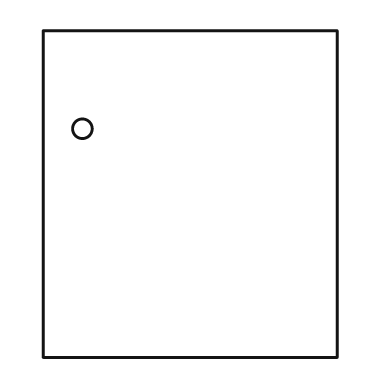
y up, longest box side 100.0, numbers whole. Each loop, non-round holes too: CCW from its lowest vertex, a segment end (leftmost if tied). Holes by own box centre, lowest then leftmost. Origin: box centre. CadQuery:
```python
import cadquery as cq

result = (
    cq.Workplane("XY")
    .moveTo(-45.0, -50.0)
    .lineTo(45.0, -50.0)
    .lineTo(45.0, 50.0)
    .lineTo(-45.0, 50.0)
    .close()
    .moveTo(-33.0, 20.0)
    .circle(3.0)
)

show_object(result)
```